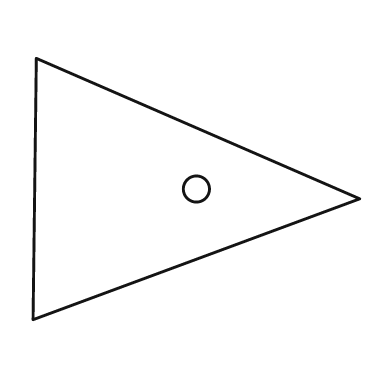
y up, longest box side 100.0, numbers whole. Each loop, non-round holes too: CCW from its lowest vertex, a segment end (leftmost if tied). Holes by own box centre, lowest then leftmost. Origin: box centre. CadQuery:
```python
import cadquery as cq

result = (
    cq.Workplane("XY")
    .moveTo(-50.0, -40.0)
    .lineTo(50.0, -3.0)
    .lineTo(-49.0, 40.0)
    .close()
    .moveTo(0.0, 0.0)
    .circle(4.0)
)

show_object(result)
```